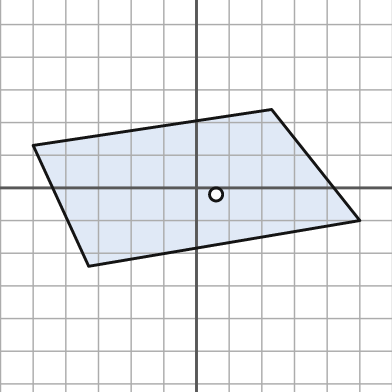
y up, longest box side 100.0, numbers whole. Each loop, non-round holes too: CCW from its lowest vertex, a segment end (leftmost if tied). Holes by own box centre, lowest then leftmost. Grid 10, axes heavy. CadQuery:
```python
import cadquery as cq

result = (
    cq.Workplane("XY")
    .moveTo(-33.0, -24.0)
    .lineTo(50.0, -10.0)
    .lineTo(23.0, 24.0)
    .lineTo(-50.0, 13.0)
    .close()
    .moveTo(6.0, -2.0)
    .circle(2.0)
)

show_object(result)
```